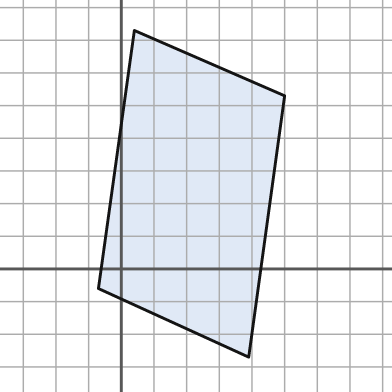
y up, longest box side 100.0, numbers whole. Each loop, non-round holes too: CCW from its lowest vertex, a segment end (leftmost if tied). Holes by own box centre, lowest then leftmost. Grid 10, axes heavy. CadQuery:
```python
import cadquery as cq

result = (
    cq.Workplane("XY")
    .moveTo(39.0, -27.0)
    .lineTo(50.0, 53.0)
    .lineTo(4.0, 73.0)
    .lineTo(-7.0, -6.0)
    .close()
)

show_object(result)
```